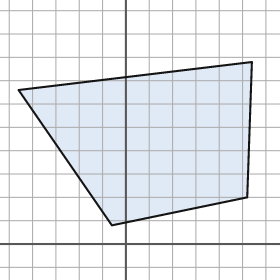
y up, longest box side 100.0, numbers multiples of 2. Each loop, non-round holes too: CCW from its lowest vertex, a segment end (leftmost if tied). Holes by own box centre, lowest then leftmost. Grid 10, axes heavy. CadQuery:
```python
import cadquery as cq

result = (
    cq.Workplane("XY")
    .moveTo(-6.0, 8.0)
    .lineTo(52.0, 20.0)
    .lineTo(54.0, 78.0)
    .lineTo(-46.0, 66.0)
    .close()
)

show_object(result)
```